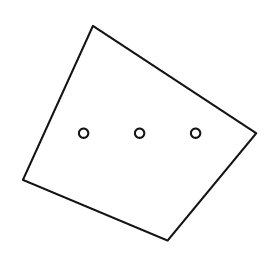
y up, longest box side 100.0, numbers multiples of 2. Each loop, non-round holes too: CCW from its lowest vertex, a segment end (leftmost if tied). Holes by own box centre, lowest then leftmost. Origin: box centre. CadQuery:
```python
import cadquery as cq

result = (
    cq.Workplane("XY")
    .moveTo(12.0, -46.0)
    .lineTo(50.0, 0.0)
    .lineTo(-20.0, 46.0)
    .lineTo(-50.0, -20.0)
    .close()
    .moveTo(-24.0, 0.0)
    .circle(2.0)
    .moveTo(0.0, 0.0)
    .circle(2.0)
    .moveTo(24.0, 0.0)
    .circle(2.0)
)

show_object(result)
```